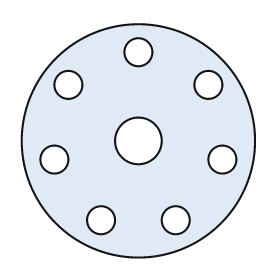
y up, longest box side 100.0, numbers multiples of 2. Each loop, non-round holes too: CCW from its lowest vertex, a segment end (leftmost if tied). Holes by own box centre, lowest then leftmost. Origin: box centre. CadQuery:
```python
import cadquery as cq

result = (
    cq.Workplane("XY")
    .moveTo(0.0, 0.0)
    .circle(50.0)
    .moveTo(-16.0, -34.0)
    .circle(6.0)
    .moveTo(16.0, -34.0)
    .circle(6.0)
    .moveTo(-36.0, -8.0)
    .circle(6.0)
    .moveTo(36.0, -8.0)
    .circle(6.0)
    .moveTo(0.0, 0.0)
    .circle(10.0)
    .moveTo(-30.0, 24.0)
    .circle(6.0)
    .moveTo(30.0, 24.0)
    .circle(6.0)
    .moveTo(0.0, 38.0)
    .circle(6.0)
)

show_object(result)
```